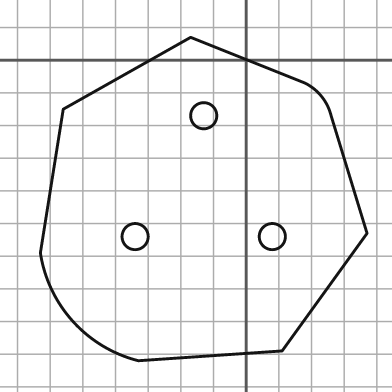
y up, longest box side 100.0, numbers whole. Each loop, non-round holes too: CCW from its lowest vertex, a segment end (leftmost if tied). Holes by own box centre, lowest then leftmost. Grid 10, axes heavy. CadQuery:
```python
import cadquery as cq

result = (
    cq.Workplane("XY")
    .moveTo(-33.0, -92.0)
    .lineTo(11.0, -89.0)
    .lineTo(37.0, -53.0)
    .lineTo(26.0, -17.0)
    .threePointArc((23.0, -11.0), (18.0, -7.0))
    .lineTo(-17.0, 7.0)
    .lineTo(-56.0, -15.0)
    .lineTo(-63.0, -59.0)
    .threePointArc((-53.0, -80.0), (-33.0, -92.0))
    .close()
    .moveTo(-34.0, -54.0)
    .circle(4.0)
    .moveTo(8.0, -54.0)
    .circle(4.0)
    .moveTo(-13.0, -17.0)
    .circle(4.0)
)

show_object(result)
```